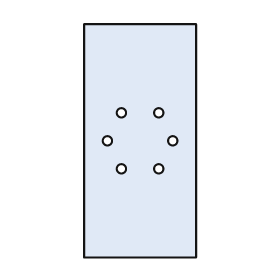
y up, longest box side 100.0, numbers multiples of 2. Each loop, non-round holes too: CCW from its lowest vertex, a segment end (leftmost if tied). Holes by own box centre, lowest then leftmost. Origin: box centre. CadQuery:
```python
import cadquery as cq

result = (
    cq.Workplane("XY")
    .moveTo(-24.0, -50.0)
    .lineTo(24.0, -50.0)
    .lineTo(24.0, 50.0)
    .lineTo(-24.0, 50.0)
    .close()
    .moveTo(-8.0, -12.0)
    .circle(2.0)
    .moveTo(8.0, -12.0)
    .circle(2.0)
    .moveTo(-14.0, 0.0)
    .circle(2.0)
    .moveTo(14.0, 0.0)
    .circle(2.0)
    .moveTo(-8.0, 12.0)
    .circle(2.0)
    .moveTo(8.0, 12.0)
    .circle(2.0)
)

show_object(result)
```